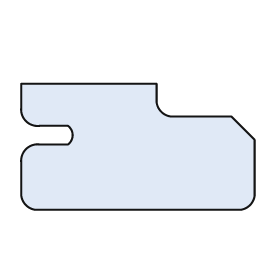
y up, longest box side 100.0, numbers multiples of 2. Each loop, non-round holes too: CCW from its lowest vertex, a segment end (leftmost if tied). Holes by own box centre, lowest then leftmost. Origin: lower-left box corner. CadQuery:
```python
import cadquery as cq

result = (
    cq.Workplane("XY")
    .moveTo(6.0, 0.0)
    .lineTo(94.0, 0.0)
    .threePointArc((98.0, 2.0), (100.0, 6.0))
    .lineTo(100.0, 30.0)
    .lineTo(90.0, 40.0)
    .lineTo(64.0, 40.0)
    .threePointArc((60.0, 42.0), (58.0, 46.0))
    .lineTo(58.0, 54.0)
    .lineTo(0.0, 54.0)
    .lineTo(0.0, 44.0)
    .threePointArc((2.0, 38.0), (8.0, 36.0))
    .lineTo(20.0, 36.0)
    .threePointArc((22.0, 32.0), (20.0, 28.0))
    .lineTo(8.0, 28.0)
    .threePointArc((2.0, 26.0), (0.0, 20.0))
    .lineTo(0.0, 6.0)
    .threePointArc((2.0, 2.0), (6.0, 0.0))
    .close()
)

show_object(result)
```